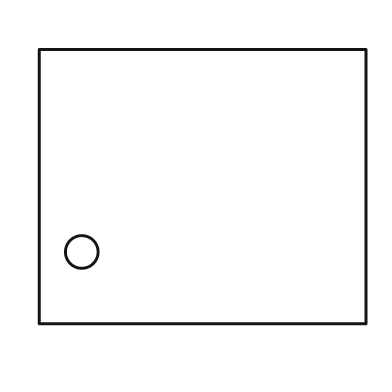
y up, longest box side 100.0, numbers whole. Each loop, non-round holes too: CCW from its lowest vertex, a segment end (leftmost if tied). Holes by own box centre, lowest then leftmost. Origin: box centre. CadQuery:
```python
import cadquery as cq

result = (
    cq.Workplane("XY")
    .moveTo(-50.0, -42.0)
    .lineTo(50.0, -42.0)
    .lineTo(50.0, 42.0)
    .lineTo(-50.0, 42.0)
    .close()
    .moveTo(-37.0, -20.0)
    .circle(5.0)
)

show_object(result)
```